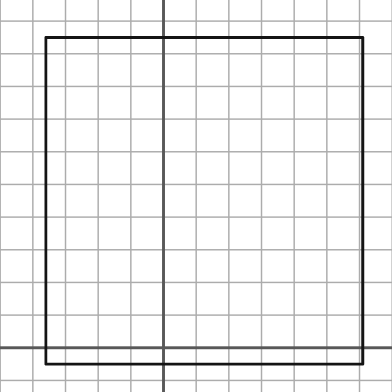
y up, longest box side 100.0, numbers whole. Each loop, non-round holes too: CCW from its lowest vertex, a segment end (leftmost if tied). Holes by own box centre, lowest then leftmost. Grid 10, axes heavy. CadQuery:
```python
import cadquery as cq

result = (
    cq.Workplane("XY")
    .moveTo(-36.0, -5.0)
    .lineTo(61.0, -5.0)
    .lineTo(61.0, 95.0)
    .lineTo(-36.0, 95.0)
    .close()
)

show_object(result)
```